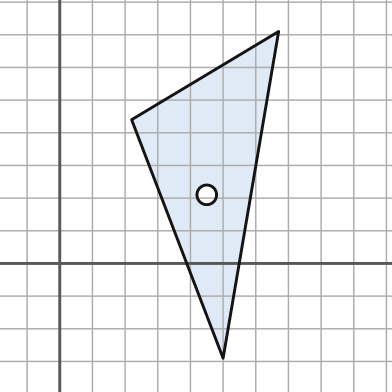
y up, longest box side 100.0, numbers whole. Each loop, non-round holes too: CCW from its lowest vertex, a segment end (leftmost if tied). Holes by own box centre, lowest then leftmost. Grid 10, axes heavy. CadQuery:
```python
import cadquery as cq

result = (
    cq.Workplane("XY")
    .moveTo(50.0, -29.0)
    .lineTo(67.0, 71.0)
    .lineTo(22.0, 44.0)
    .close()
    .moveTo(45.0, 21.0)
    .circle(3.0)
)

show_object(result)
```